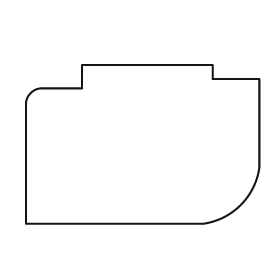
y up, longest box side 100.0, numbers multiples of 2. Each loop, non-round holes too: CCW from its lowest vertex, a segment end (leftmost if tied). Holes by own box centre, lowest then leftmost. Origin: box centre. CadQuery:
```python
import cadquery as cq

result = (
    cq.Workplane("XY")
    .moveTo(-50.0, -34.0)
    .lineTo(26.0, -34.0)
    .threePointArc((42.0, -26.0), (50.0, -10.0))
    .lineTo(50.0, 28.0)
    .lineTo(30.0, 28.0)
    .lineTo(30.0, 34.0)
    .lineTo(-26.0, 34.0)
    .lineTo(-26.0, 24.0)
    .lineTo(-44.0, 24.0)
    .threePointArc((-48.0, 22.0), (-50.0, 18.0))
    .close()
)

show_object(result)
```